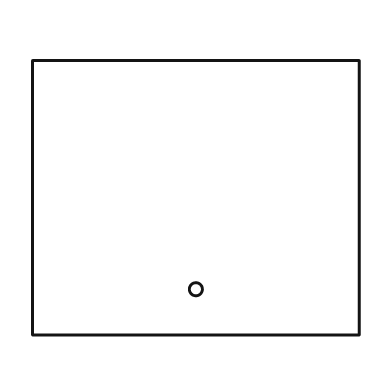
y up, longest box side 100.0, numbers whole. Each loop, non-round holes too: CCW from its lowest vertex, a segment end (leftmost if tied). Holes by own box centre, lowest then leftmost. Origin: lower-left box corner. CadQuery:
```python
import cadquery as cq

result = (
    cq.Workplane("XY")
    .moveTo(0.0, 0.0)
    .lineTo(100.0, 0.0)
    .lineTo(100.0, 84.0)
    .lineTo(0.0, 84.0)
    .close()
    .moveTo(50.0, 14.0)
    .circle(2.0)
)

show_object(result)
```